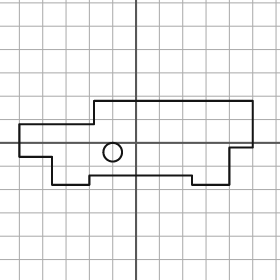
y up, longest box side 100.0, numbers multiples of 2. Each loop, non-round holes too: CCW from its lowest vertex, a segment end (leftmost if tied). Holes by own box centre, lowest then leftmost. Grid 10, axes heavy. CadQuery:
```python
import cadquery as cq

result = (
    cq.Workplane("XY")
    .moveTo(-36.0, -18.0)
    .lineTo(-20.0, -18.0)
    .lineTo(-20.0, -14.0)
    .lineTo(24.0, -14.0)
    .lineTo(24.0, -18.0)
    .lineTo(40.0, -18.0)
    .lineTo(40.0, -2.0)
    .lineTo(50.0, -2.0)
    .lineTo(50.0, 18.0)
    .lineTo(-18.0, 18.0)
    .lineTo(-18.0, 8.0)
    .lineTo(-50.0, 8.0)
    .lineTo(-50.0, -6.0)
    .lineTo(-36.0, -6.0)
    .close()
    .moveTo(-10.0, -4.0)
    .circle(4.0)
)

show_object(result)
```